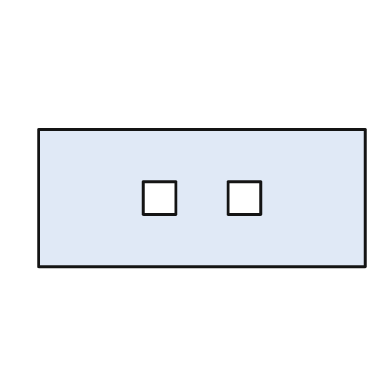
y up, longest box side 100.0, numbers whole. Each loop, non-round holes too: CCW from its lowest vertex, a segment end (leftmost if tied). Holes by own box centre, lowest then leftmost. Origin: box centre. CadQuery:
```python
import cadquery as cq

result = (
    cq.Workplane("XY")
    .moveTo(-50.0, -21.0)
    .lineTo(50.0, -21.0)
    .lineTo(50.0, 21.0)
    .lineTo(-50.0, 21.0)
    .close()
    .moveTo(-18.0, -5.0)
    .lineTo(-8.0, -5.0)
    .lineTo(-8.0, 5.0)
    .lineTo(-18.0, 5.0)
    .close()
    .moveTo(8.0, -5.0)
    .lineTo(18.0, -5.0)
    .lineTo(18.0, 5.0)
    .lineTo(8.0, 5.0)
    .close()
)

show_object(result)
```